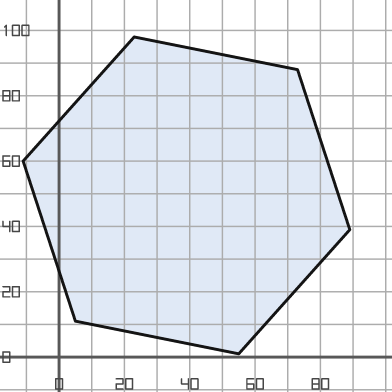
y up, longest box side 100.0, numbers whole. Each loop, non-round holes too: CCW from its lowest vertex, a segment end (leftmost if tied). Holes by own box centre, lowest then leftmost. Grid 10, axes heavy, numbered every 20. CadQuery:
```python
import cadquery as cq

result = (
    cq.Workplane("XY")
    .moveTo(55.0, 1.0)
    .lineTo(89.0, 39.0)
    .lineTo(73.0, 88.0)
    .lineTo(23.0, 98.0)
    .lineTo(-11.0, 60.0)
    .lineTo(5.0, 11.0)
    .close()
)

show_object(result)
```